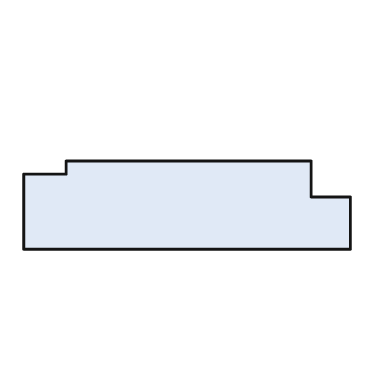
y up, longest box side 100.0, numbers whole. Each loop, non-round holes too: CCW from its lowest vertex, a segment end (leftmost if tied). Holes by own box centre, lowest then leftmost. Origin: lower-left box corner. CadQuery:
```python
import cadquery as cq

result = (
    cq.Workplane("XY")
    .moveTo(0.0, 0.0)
    .lineTo(100.0, 0.0)
    .lineTo(100.0, 16.0)
    .lineTo(88.0, 16.0)
    .lineTo(88.0, 27.0)
    .lineTo(13.0, 27.0)
    .lineTo(13.0, 23.0)
    .lineTo(0.0, 23.0)
    .close()
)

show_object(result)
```